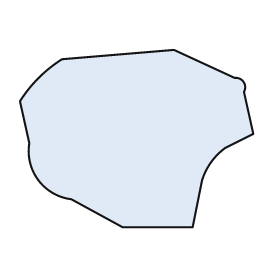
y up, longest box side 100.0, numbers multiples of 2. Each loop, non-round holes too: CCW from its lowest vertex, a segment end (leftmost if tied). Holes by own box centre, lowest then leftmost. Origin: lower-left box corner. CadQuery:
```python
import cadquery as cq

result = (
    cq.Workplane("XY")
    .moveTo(44.0, 0.0)
    .lineTo(74.0, 0.0)
    .lineTo(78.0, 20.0)
    .threePointArc((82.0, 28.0), (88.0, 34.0))
    .lineTo(100.0, 40.0)
    .lineTo(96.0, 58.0)
    .threePointArc((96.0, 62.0), (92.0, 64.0))
    .lineTo(66.0, 76.0)
    .lineTo(18.0, 72.0)
    .threePointArc((8.0, 64.0), (0.0, 54.0))
    .lineTo(4.0, 36.0)
    .threePointArc((8.0, 20.0), (22.0, 12.0))
    .close()
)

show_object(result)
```